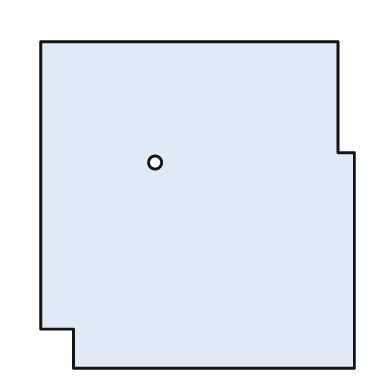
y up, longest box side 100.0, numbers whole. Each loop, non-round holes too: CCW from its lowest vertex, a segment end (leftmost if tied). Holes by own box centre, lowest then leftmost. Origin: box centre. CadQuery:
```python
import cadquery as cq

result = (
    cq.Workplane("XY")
    .moveTo(-38.0, -50.0)
    .lineTo(48.0, -50.0)
    .lineTo(48.0, 16.0)
    .lineTo(43.0, 16.0)
    .lineTo(43.0, 50.0)
    .lineTo(-48.0, 50.0)
    .lineTo(-48.0, -38.0)
    .lineTo(-38.0, -38.0)
    .close()
    .moveTo(-13.0, 13.0)
    .circle(2.0)
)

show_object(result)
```